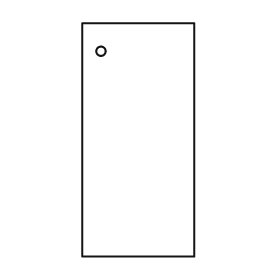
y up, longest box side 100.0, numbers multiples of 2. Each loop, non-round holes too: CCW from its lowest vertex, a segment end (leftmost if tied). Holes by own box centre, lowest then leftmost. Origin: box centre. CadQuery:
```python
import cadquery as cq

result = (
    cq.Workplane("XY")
    .moveTo(-24.0, -50.0)
    .lineTo(24.0, -50.0)
    .lineTo(24.0, 50.0)
    .lineTo(-24.0, 50.0)
    .close()
    .moveTo(-16.0, 38.0)
    .circle(2.0)
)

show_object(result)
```